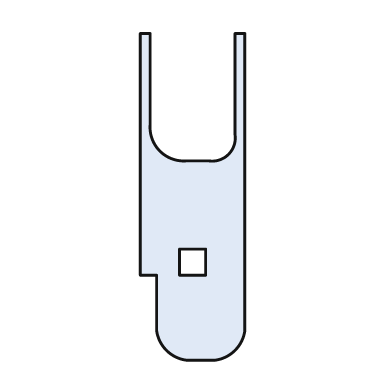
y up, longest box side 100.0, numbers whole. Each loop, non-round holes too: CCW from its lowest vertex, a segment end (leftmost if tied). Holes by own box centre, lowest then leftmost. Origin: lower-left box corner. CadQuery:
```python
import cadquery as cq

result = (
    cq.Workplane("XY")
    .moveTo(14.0, 0.0)
    .lineTo(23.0, 0.0)
    .threePointArc((29.0, 3.0), (32.0, 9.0))
    .lineTo(32.0, 100.0)
    .lineTo(29.0, 100.0)
    .lineTo(29.0, 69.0)
    .threePointArc((27.0, 63.0), (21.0, 61.0))
    .lineTo(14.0, 61.0)
    .threePointArc((6.0, 64.0), (3.0, 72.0))
    .lineTo(3.0, 100.0)
    .lineTo(0.0, 100.0)
    .lineTo(0.0, 26.0)
    .lineTo(5.0, 26.0)
    .lineTo(5.0, 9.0)
    .threePointArc((8.0, 3.0), (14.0, 0.0))
    .close()
    .moveTo(12.0, 26.0)
    .lineTo(20.0, 26.0)
    .lineTo(20.0, 34.0)
    .lineTo(12.0, 34.0)
    .close()
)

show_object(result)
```